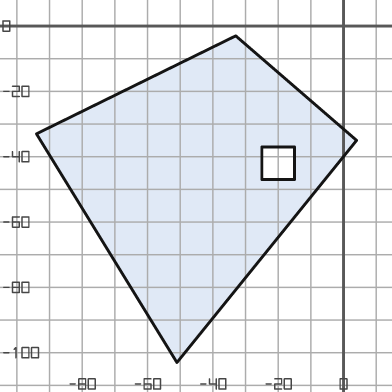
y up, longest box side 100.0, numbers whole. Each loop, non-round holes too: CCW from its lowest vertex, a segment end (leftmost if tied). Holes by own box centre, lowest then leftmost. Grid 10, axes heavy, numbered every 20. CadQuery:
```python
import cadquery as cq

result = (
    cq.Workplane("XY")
    .moveTo(-51.0, -103.0)
    .lineTo(4.0, -35.0)
    .lineTo(-33.0, -3.0)
    .lineTo(-94.0, -33.0)
    .close()
    .moveTo(-25.0, -47.0)
    .lineTo(-15.0, -47.0)
    .lineTo(-15.0, -37.0)
    .lineTo(-25.0, -37.0)
    .close()
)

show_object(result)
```